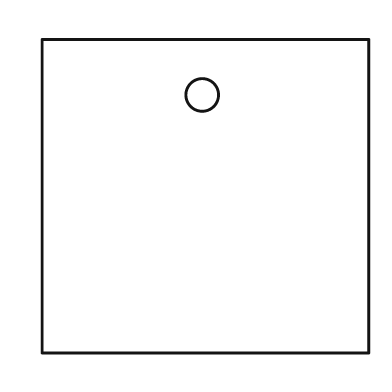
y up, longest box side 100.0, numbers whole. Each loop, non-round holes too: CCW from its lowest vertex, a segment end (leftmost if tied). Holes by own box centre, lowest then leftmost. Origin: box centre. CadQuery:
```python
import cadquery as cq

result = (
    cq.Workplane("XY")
    .moveTo(-50.0, -48.0)
    .lineTo(50.0, -48.0)
    .lineTo(50.0, 48.0)
    .lineTo(-50.0, 48.0)
    .close()
    .moveTo(-1.0, 31.0)
    .circle(5.0)
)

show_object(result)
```